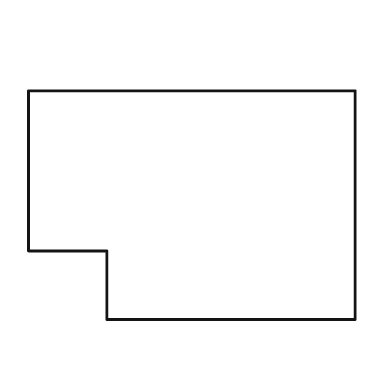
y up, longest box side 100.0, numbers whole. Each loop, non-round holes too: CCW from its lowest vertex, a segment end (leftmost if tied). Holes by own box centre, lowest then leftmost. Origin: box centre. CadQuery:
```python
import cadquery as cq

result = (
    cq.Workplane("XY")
    .moveTo(-26.0, -35.0)
    .lineTo(50.0, -35.0)
    .lineTo(50.0, 35.0)
    .lineTo(-50.0, 35.0)
    .lineTo(-50.0, -14.0)
    .lineTo(-26.0, -14.0)
    .close()
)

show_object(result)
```